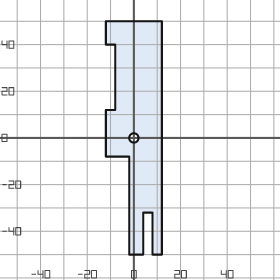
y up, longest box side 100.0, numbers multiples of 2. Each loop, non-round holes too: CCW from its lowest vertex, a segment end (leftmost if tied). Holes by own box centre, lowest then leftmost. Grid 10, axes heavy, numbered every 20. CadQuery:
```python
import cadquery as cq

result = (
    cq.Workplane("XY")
    .moveTo(-2.0, -50.0)
    .lineTo(4.0, -50.0)
    .lineTo(4.0, -32.0)
    .lineTo(8.0, -32.0)
    .lineTo(8.0, -50.0)
    .lineTo(12.0, -50.0)
    .lineTo(12.0, 50.0)
    .lineTo(-12.0, 50.0)
    .lineTo(-12.0, 40.0)
    .lineTo(-8.0, 40.0)
    .lineTo(-8.0, 12.0)
    .lineTo(-12.0, 12.0)
    .lineTo(-12.0, -8.0)
    .lineTo(-2.0, -8.0)
    .close()
    .moveTo(0.0, 0.0)
    .circle(2.0)
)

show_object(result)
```